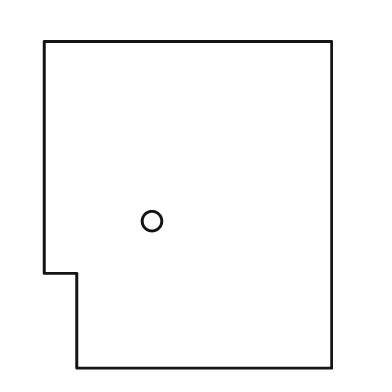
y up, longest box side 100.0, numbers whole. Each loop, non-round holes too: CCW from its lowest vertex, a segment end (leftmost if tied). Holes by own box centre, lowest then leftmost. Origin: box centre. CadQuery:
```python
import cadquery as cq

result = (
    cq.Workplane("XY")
    .moveTo(-34.0, -50.0)
    .lineTo(44.0, -50.0)
    .lineTo(44.0, 50.0)
    .lineTo(-44.0, 50.0)
    .lineTo(-44.0, -21.0)
    .lineTo(-34.0, -21.0)
    .close()
    .moveTo(-11.0, -5.0)
    .circle(3.0)
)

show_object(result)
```